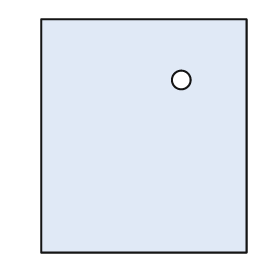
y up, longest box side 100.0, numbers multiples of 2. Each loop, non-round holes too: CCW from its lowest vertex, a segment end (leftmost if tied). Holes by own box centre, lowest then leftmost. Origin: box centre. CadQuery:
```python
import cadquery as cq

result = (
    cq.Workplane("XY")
    .moveTo(-44.0, -50.0)
    .lineTo(44.0, -50.0)
    .lineTo(44.0, 50.0)
    .lineTo(-44.0, 50.0)
    .close()
    .moveTo(16.0, 24.0)
    .circle(4.0)
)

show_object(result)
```